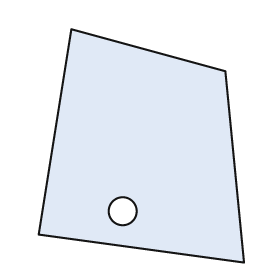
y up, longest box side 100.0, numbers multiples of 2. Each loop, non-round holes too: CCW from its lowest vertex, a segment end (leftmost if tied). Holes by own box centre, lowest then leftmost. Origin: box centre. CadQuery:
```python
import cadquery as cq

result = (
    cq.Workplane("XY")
    .moveTo(44.0, -50.0)
    .lineTo(36.0, 32.0)
    .lineTo(-30.0, 50.0)
    .lineTo(-44.0, -38.0)
    .close()
    .moveTo(-8.0, -28.0)
    .circle(6.0)
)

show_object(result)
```